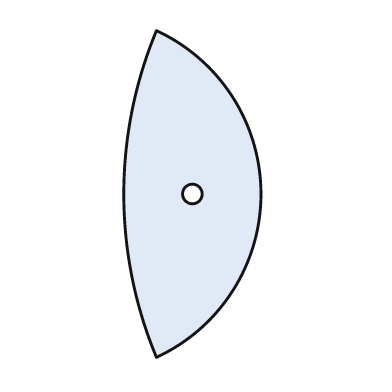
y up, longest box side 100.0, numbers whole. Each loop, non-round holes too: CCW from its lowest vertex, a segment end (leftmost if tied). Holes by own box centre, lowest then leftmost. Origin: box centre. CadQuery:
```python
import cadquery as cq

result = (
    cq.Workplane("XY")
    .moveTo(-11.0, -50.0)
    .threePointArc((21.0, 0.0), (-11.0, 50.0))
    .threePointArc((-21.0, 0.0), (-11.0, -50.0))
    .close()
    .moveTo(0.0, 0.0)
    .circle(3.0)
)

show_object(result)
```